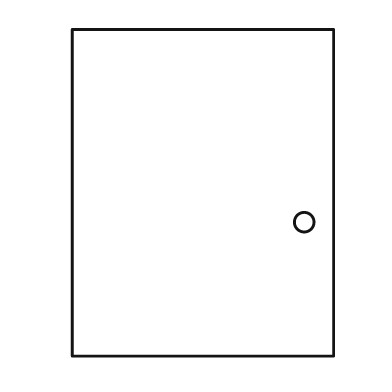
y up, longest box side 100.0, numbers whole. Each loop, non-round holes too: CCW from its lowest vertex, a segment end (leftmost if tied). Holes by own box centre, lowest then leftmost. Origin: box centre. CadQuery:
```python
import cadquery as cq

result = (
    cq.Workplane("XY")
    .moveTo(-40.0, -50.0)
    .lineTo(40.0, -50.0)
    .lineTo(40.0, 50.0)
    .lineTo(-40.0, 50.0)
    .close()
    .moveTo(31.0, -9.0)
    .circle(3.0)
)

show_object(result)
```